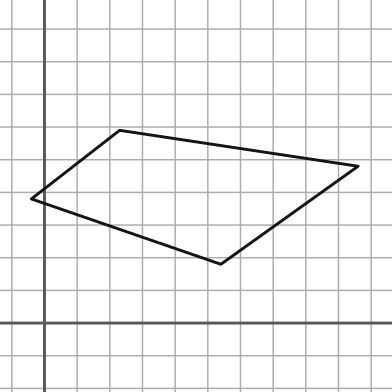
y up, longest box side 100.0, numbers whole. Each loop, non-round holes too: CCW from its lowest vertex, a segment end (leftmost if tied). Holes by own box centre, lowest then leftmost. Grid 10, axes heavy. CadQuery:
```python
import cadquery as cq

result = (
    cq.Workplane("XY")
    .moveTo(54.0, 18.0)
    .lineTo(96.0, 48.0)
    .lineTo(23.0, 59.0)
    .lineTo(-4.0, 38.0)
    .close()
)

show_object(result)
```